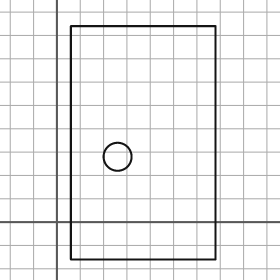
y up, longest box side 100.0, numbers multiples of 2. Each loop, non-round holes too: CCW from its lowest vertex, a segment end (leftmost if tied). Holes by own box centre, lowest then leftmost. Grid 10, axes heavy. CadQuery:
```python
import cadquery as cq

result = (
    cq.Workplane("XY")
    .moveTo(6.0, -16.0)
    .lineTo(68.0, -16.0)
    .lineTo(68.0, 84.0)
    .lineTo(6.0, 84.0)
    .close()
    .moveTo(26.0, 28.0)
    .circle(6.0)
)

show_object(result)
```